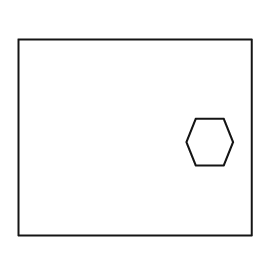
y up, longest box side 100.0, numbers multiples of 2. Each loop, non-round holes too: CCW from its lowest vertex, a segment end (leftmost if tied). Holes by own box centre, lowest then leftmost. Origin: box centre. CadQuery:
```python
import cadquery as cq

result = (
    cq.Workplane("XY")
    .moveTo(-50.0, -42.0)
    .lineTo(50.0, -42.0)
    .lineTo(50.0, 42.0)
    .lineTo(-50.0, 42.0)
    .close()
    .moveTo(26.0, -12.0)
    .lineTo(38.0, -12.0)
    .lineTo(42.0, -2.0)
    .lineTo(38.0, 8.0)
    .lineTo(26.0, 8.0)
    .lineTo(22.0, -2.0)
    .close()
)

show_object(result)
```